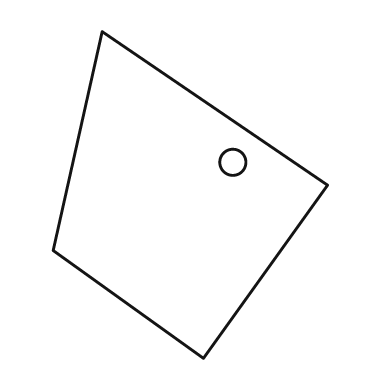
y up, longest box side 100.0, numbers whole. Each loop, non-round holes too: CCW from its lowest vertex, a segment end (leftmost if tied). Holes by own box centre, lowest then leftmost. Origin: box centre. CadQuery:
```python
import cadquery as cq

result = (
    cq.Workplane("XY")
    .moveTo(4.0, -50.0)
    .lineTo(42.0, 3.0)
    .lineTo(-27.0, 50.0)
    .lineTo(-42.0, -17.0)
    .close()
    .moveTo(13.0, 10.0)
    .circle(4.0)
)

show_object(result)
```